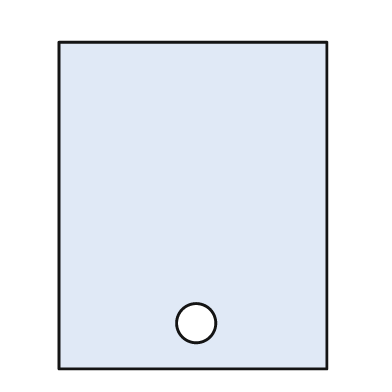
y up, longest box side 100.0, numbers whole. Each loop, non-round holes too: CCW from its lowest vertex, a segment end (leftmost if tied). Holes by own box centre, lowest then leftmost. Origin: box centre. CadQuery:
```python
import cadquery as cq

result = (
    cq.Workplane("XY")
    .moveTo(-41.0, -50.0)
    .lineTo(41.0, -50.0)
    .lineTo(41.0, 50.0)
    .lineTo(-41.0, 50.0)
    .close()
    .moveTo(1.0, -36.0)
    .circle(6.0)
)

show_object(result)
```